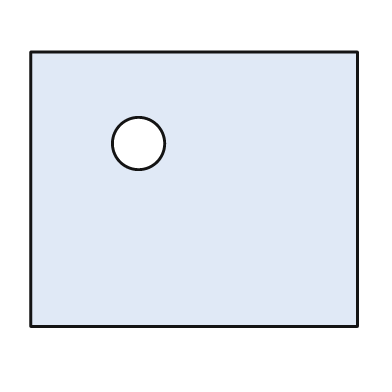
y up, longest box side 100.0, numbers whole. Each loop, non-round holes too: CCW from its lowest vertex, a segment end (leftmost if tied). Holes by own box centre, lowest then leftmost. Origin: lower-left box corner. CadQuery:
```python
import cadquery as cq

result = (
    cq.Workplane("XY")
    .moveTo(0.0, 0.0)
    .lineTo(100.0, 0.0)
    .lineTo(100.0, 84.0)
    .lineTo(0.0, 84.0)
    .close()
    .moveTo(33.0, 56.0)
    .circle(8.0)
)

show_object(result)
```